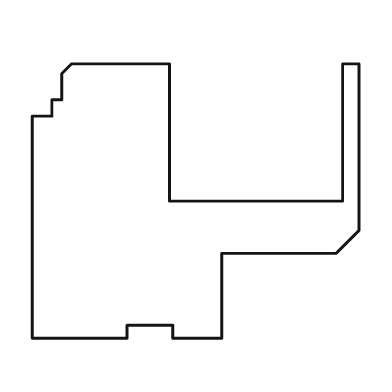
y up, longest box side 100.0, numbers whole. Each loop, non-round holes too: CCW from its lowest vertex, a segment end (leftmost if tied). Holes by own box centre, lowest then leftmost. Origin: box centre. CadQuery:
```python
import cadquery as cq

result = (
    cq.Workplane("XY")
    .moveTo(-50.0, -42.0)
    .lineTo(-21.0, -42.0)
    .lineTo(-21.0, -38.0)
    .lineTo(-7.0, -38.0)
    .lineTo(-7.0, -42.0)
    .lineTo(8.0, -42.0)
    .lineTo(8.0, -16.0)
    .lineTo(43.0, -16.0)
    .lineTo(50.0, -9.0)
    .lineTo(50.0, 42.0)
    .lineTo(45.0, 42.0)
    .lineTo(45.0, 0.0)
    .lineTo(-8.0, 0.0)
    .lineTo(-8.0, 42.0)
    .lineTo(-38.0, 42.0)
    .lineTo(-41.0, 39.0)
    .lineTo(-41.0, 31.0)
    .lineTo(-44.0, 31.0)
    .lineTo(-44.0, 26.0)
    .lineTo(-50.0, 26.0)
    .close()
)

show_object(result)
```